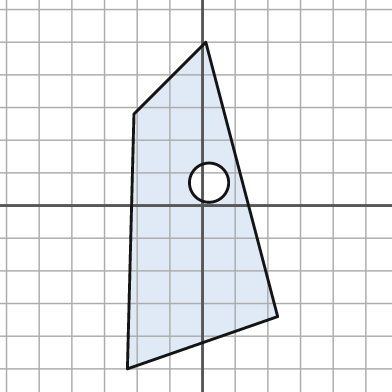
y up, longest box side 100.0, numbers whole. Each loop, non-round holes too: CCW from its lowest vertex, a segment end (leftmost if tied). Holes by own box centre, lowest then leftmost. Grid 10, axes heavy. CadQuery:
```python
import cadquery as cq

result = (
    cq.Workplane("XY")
    .moveTo(-23.0, -50.0)
    .lineTo(23.0, -34.0)
    .lineTo(1.0, 50.0)
    .lineTo(-21.0, 28.0)
    .close()
    .moveTo(2.0, 7.0)
    .circle(6.0)
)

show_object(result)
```